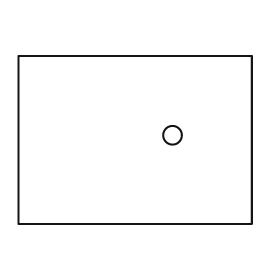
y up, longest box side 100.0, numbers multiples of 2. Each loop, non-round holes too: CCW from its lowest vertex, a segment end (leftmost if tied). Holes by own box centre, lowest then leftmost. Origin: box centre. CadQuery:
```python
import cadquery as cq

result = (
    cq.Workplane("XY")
    .moveTo(-50.0, -36.0)
    .lineTo(50.0, -36.0)
    .lineTo(50.0, 36.0)
    .lineTo(-50.0, 36.0)
    .close()
    .moveTo(16.0, 2.0)
    .circle(4.0)
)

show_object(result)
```